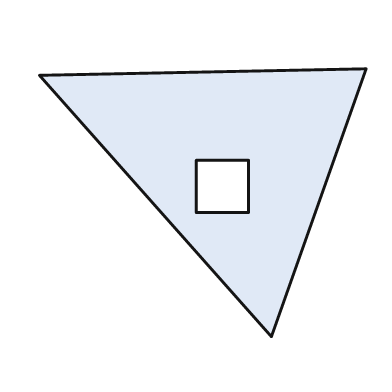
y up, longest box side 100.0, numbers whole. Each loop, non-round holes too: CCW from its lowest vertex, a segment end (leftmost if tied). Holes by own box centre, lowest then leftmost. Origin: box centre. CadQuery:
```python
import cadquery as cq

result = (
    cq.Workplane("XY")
    .moveTo(21.0, -41.0)
    .lineTo(50.0, 41.0)
    .lineTo(-50.0, 39.0)
    .close()
    .moveTo(-2.0, -3.0)
    .lineTo(14.0, -3.0)
    .lineTo(14.0, 13.0)
    .lineTo(-2.0, 13.0)
    .close()
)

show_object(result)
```